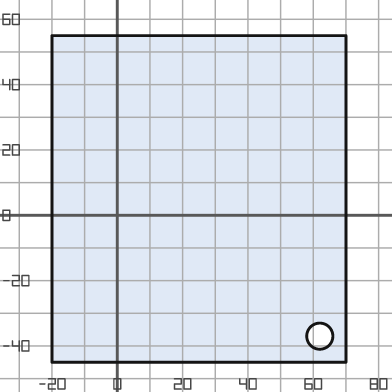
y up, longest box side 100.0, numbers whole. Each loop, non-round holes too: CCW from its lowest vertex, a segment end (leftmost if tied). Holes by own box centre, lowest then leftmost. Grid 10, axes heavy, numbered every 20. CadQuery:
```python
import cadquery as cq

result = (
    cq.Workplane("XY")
    .moveTo(-20.0, -45.0)
    .lineTo(70.0, -45.0)
    .lineTo(70.0, 55.0)
    .lineTo(-20.0, 55.0)
    .close()
    .moveTo(62.0, -37.0)
    .circle(4.0)
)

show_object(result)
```